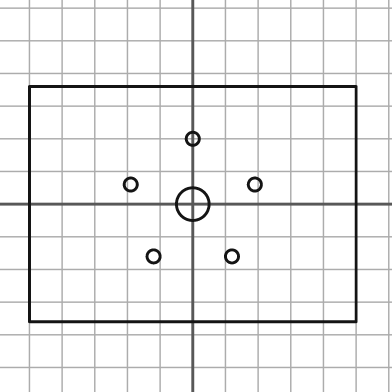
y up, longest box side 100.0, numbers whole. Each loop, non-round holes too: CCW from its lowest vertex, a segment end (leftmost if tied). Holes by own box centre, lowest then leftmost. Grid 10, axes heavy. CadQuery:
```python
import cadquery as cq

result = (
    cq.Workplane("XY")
    .moveTo(-50.0, -36.0)
    .lineTo(50.0, -36.0)
    .lineTo(50.0, 36.0)
    .lineTo(-50.0, 36.0)
    .close()
    .moveTo(-12.0, -16.0)
    .circle(2.0)
    .moveTo(12.0, -16.0)
    .circle(2.0)
    .moveTo(0.0, 0.0)
    .circle(5.0)
    .moveTo(-19.0, 6.0)
    .circle(2.0)
    .moveTo(19.0, 6.0)
    .circle(2.0)
    .moveTo(0.0, 20.0)
    .circle(2.0)
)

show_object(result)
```